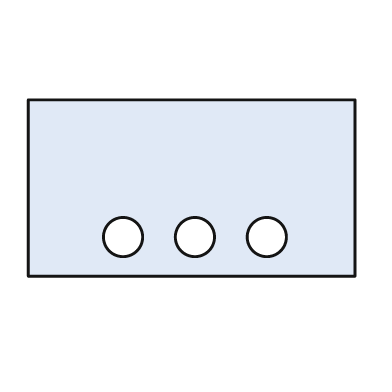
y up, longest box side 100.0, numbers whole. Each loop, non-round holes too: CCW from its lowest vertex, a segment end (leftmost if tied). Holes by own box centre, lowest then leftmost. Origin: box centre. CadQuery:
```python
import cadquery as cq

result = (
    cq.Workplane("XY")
    .moveTo(-50.0, -27.0)
    .lineTo(50.0, -27.0)
    .lineTo(50.0, 27.0)
    .lineTo(-50.0, 27.0)
    .close()
    .moveTo(-21.0, -15.0)
    .circle(6.0)
    .moveTo(1.0, -15.0)
    .circle(6.0)
    .moveTo(23.0, -15.0)
    .circle(6.0)
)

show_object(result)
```